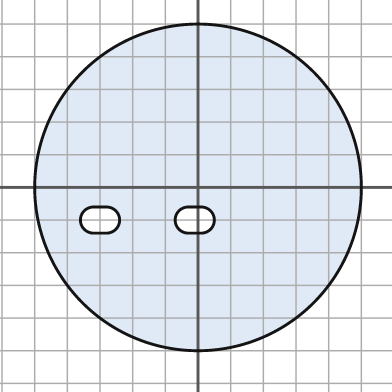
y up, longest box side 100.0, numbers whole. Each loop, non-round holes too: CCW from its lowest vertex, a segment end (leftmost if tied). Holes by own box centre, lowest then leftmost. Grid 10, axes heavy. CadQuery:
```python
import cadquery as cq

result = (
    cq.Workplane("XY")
    .moveTo(0.0, 0.0)
    .circle(50.0)
    .moveTo(-32.0, -14.0)
    .lineTo(-28.0, -14.0)
    .threePointArc((-24.0, -10.0), (-28.0, -6.0))
    .lineTo(-32.0, -6.0)
    .threePointArc((-36.0, -10.0), (-32.0, -14.0))
    .close()
    .moveTo(-3.0, -14.0)
    .lineTo(1.0, -14.0)
    .threePointArc((5.0, -10.0), (1.0, -6.0))
    .lineTo(-3.0, -6.0)
    .threePointArc((-7.0, -10.0), (-3.0, -14.0))
    .close()
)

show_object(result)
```